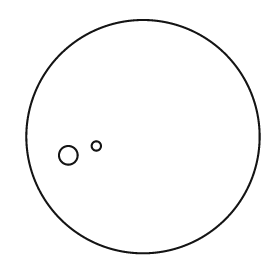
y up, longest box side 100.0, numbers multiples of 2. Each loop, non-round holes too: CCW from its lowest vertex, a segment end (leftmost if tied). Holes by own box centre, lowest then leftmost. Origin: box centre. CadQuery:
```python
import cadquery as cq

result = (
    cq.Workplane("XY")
    .moveTo(0.0, 0.0)
    .circle(50.0)
    .moveTo(-32.0, -8.0)
    .circle(4.0)
    .moveTo(-20.0, -4.0)
    .circle(2.0)
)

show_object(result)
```